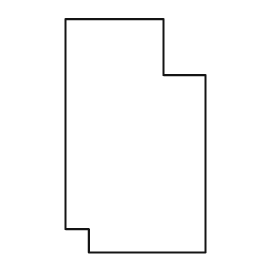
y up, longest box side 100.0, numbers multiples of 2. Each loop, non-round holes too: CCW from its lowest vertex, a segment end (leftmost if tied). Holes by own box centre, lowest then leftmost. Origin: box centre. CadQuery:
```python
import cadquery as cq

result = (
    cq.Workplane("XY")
    .moveTo(-20.0, -50.0)
    .lineTo(30.0, -50.0)
    .lineTo(30.0, 26.0)
    .lineTo(12.0, 26.0)
    .lineTo(12.0, 50.0)
    .lineTo(-30.0, 50.0)
    .lineTo(-30.0, -40.0)
    .lineTo(-20.0, -40.0)
    .close()
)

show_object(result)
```